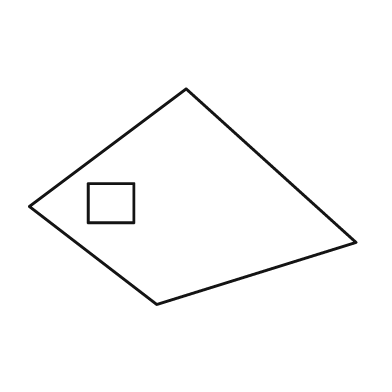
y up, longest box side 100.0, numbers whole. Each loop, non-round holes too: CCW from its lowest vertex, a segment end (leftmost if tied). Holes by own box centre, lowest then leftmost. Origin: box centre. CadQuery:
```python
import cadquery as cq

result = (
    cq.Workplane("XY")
    .moveTo(-11.0, -33.0)
    .lineTo(50.0, -14.0)
    .lineTo(-2.0, 33.0)
    .lineTo(-50.0, -3.0)
    .close()
    .moveTo(-32.0, -8.0)
    .lineTo(-18.0, -8.0)
    .lineTo(-18.0, 4.0)
    .lineTo(-32.0, 4.0)
    .close()
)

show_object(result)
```